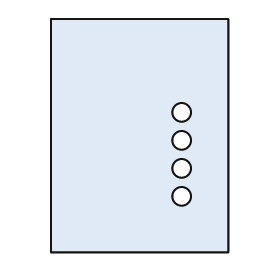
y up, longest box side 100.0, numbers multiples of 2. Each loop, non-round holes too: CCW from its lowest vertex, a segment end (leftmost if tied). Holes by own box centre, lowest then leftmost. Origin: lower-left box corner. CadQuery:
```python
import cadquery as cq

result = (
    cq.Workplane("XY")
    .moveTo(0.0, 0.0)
    .lineTo(76.0, 0.0)
    .lineTo(76.0, 100.0)
    .lineTo(0.0, 100.0)
    .close()
    .moveTo(56.0, 24.0)
    .circle(4.0)
    .moveTo(56.0, 36.0)
    .circle(4.0)
    .moveTo(56.0, 48.0)
    .circle(4.0)
    .moveTo(56.0, 60.0)
    .circle(4.0)
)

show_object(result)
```